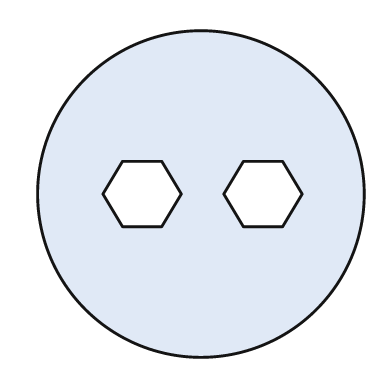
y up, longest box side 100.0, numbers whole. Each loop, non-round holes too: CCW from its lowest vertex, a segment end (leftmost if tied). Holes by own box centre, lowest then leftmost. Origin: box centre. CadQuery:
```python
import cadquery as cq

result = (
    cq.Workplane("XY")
    .moveTo(0.0, 0.0)
    .circle(50.0)
    .moveTo(-24.0, -10.0)
    .lineTo(-12.0, -10.0)
    .lineTo(-6.0, 0.0)
    .lineTo(-12.0, 10.0)
    .lineTo(-24.0, 10.0)
    .lineTo(-30.0, 0.0)
    .close()
    .moveTo(13.0, -10.0)
    .lineTo(25.0, -10.0)
    .lineTo(31.0, 0.0)
    .lineTo(25.0, 10.0)
    .lineTo(13.0, 10.0)
    .lineTo(7.0, 0.0)
    .close()
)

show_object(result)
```